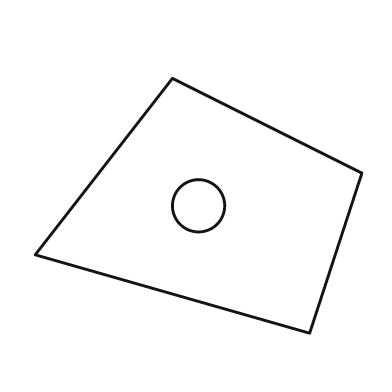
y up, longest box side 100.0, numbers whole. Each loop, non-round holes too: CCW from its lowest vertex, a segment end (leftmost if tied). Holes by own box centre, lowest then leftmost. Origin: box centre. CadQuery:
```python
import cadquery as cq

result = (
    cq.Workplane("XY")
    .moveTo(34.0, -39.0)
    .lineTo(50.0, 10.0)
    .lineTo(-8.0, 39.0)
    .lineTo(-50.0, -15.0)
    .close()
    .moveTo(0.0, 0.0)
    .circle(8.0)
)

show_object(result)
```